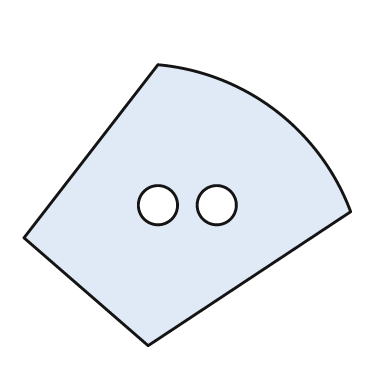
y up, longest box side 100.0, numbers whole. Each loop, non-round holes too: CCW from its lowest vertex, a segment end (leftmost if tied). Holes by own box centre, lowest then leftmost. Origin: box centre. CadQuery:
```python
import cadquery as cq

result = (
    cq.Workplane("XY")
    .moveTo(-12.0, -43.0)
    .lineTo(50.0, -2.0)
    .threePointArc((27.0, 29.0), (-9.0, 43.0))
    .lineTo(-50.0, -10.0)
    .close()
    .moveTo(-9.0, 0.0)
    .circle(6.0)
    .moveTo(9.0, 0.0)
    .circle(6.0)
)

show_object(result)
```